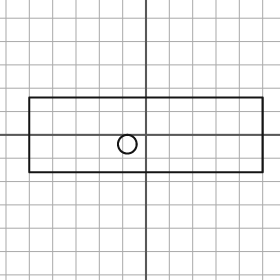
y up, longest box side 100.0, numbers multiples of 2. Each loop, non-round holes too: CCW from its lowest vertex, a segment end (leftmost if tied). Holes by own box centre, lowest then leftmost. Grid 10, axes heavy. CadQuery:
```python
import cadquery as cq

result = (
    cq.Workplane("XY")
    .moveTo(-50.0, -16.0)
    .lineTo(50.0, -16.0)
    .lineTo(50.0, 16.0)
    .lineTo(-50.0, 16.0)
    .close()
    .moveTo(-8.0, -4.0)
    .circle(4.0)
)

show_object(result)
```